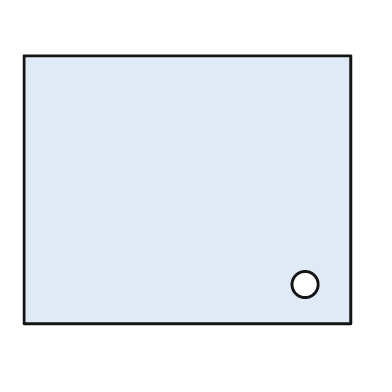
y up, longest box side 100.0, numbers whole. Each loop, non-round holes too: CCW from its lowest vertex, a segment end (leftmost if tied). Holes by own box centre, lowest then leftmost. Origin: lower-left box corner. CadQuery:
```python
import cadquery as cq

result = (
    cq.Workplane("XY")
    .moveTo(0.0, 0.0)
    .lineTo(100.0, 0.0)
    .lineTo(100.0, 82.0)
    .lineTo(0.0, 82.0)
    .close()
    .moveTo(86.0, 12.0)
    .circle(4.0)
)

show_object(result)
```